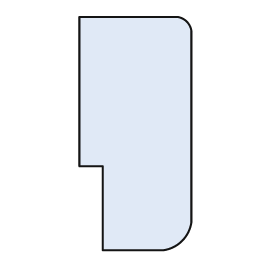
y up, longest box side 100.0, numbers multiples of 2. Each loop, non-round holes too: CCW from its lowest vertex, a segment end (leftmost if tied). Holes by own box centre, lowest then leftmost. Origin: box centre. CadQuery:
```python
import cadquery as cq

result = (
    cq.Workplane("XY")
    .moveTo(-14.0, -50.0)
    .lineTo(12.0, -50.0)
    .threePointArc((20.0, -46.0), (24.0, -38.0))
    .lineTo(24.0, 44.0)
    .threePointArc((22.0, 48.0), (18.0, 50.0))
    .lineTo(-24.0, 50.0)
    .lineTo(-24.0, -14.0)
    .lineTo(-14.0, -14.0)
    .close()
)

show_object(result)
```